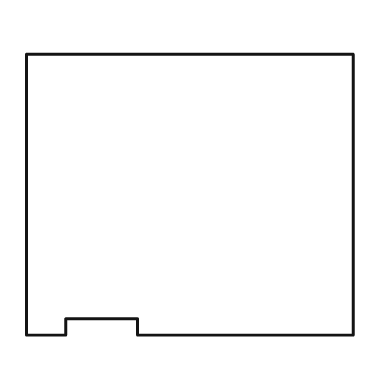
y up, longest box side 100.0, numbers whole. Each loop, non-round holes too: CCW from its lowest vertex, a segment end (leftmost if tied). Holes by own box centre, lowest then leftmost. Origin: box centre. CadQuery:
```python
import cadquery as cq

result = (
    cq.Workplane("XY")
    .moveTo(-50.0, -43.0)
    .lineTo(-38.0, -43.0)
    .lineTo(-38.0, -38.0)
    .lineTo(-16.0, -38.0)
    .lineTo(-16.0, -43.0)
    .lineTo(50.0, -43.0)
    .lineTo(50.0, 43.0)
    .lineTo(-50.0, 43.0)
    .close()
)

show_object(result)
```